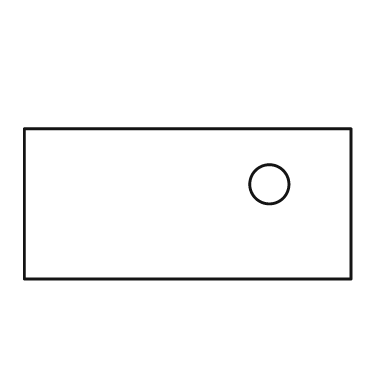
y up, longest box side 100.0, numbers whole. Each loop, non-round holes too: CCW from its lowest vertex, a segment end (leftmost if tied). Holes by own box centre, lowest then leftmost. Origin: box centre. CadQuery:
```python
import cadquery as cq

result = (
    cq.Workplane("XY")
    .moveTo(-50.0, -23.0)
    .lineTo(50.0, -23.0)
    .lineTo(50.0, 23.0)
    .lineTo(-50.0, 23.0)
    .close()
    .moveTo(25.0, 6.0)
    .circle(6.0)
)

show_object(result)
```